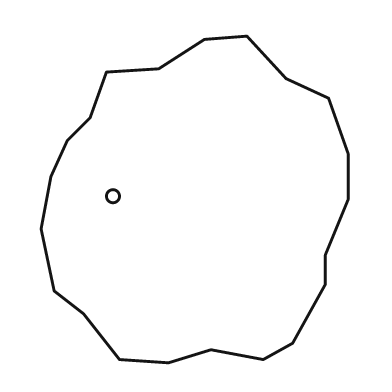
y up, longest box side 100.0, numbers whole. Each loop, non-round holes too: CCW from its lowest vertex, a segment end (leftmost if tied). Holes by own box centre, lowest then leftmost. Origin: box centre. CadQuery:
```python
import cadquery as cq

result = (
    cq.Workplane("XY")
    .moveTo(-8.0, -50.0)
    .lineTo(5.0, -46.0)
    .lineTo(21.0, -49.0)
    .lineTo(30.0, -44.0)
    .lineTo(40.0, -26.0)
    .lineTo(40.0, -17.0)
    .lineTo(47.0, 0.0)
    .lineTo(47.0, 14.0)
    .lineTo(41.0, 31.0)
    .lineTo(28.0, 37.0)
    .lineTo(16.0, 50.0)
    .lineTo(3.0, 49.0)
    .lineTo(-11.0, 40.0)
    .lineTo(-27.0, 39.0)
    .lineTo(-32.0, 25.0)
    .lineTo(-39.0, 18.0)
    .lineTo(-44.0, 7.0)
    .lineTo(-47.0, -9.0)
    .lineTo(-43.0, -28.0)
    .lineTo(-34.0, -35.0)
    .lineTo(-23.0, -49.0)
    .close()
    .moveTo(-25.0, 1.0)
    .circle(2.0)
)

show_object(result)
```